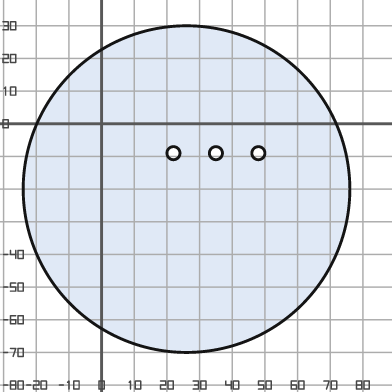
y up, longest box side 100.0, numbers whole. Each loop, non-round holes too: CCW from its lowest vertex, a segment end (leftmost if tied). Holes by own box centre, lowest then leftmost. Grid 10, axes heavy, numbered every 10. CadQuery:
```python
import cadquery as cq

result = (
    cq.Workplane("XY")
    .moveTo(26.0, -20.0)
    .circle(50.0)
    .moveTo(22.0, -9.0)
    .circle(2.0)
    .moveTo(35.0, -9.0)
    .circle(2.0)
    .moveTo(48.0, -9.0)
    .circle(2.0)
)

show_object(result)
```